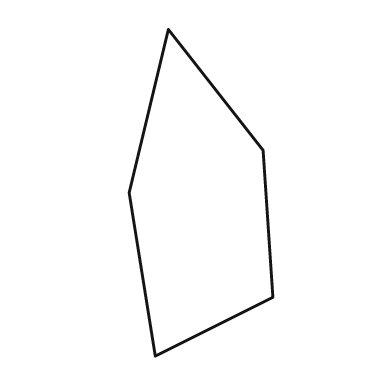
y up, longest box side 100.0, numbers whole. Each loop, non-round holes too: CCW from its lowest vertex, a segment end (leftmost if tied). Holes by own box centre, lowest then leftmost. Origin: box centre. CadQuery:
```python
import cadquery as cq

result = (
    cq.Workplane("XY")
    .moveTo(-14.0, -50.0)
    .lineTo(22.0, -32.0)
    .lineTo(19.0, 13.0)
    .lineTo(-10.0, 50.0)
    .lineTo(-22.0, 0.0)
    .close()
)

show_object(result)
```